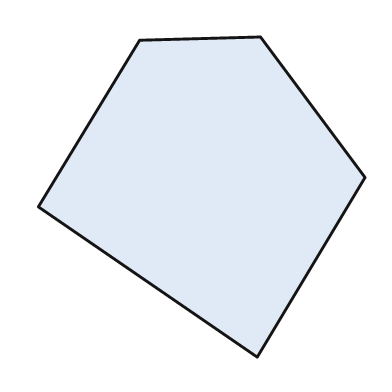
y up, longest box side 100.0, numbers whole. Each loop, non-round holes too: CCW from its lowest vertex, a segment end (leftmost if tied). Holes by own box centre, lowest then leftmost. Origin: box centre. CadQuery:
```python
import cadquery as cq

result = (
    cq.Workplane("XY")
    .moveTo(17.0, -49.0)
    .lineTo(50.0, 6.0)
    .lineTo(18.0, 49.0)
    .lineTo(-19.0, 48.0)
    .lineTo(-50.0, -3.0)
    .close()
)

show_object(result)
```